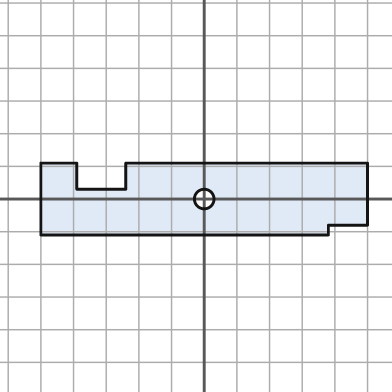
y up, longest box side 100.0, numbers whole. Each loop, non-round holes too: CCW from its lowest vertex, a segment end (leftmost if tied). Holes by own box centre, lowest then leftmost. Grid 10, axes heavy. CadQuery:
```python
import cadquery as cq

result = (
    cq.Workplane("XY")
    .moveTo(-50.0, -11.0)
    .lineTo(38.0, -11.0)
    .lineTo(38.0, -8.0)
    .lineTo(50.0, -8.0)
    .lineTo(50.0, 11.0)
    .lineTo(-24.0, 11.0)
    .lineTo(-24.0, 3.0)
    .lineTo(-39.0, 3.0)
    .lineTo(-39.0, 11.0)
    .lineTo(-50.0, 11.0)
    .close()
    .moveTo(0.0, 0.0)
    .circle(3.0)
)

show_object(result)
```